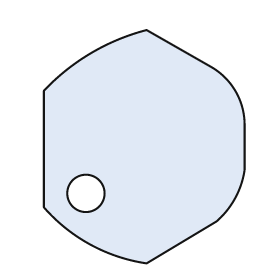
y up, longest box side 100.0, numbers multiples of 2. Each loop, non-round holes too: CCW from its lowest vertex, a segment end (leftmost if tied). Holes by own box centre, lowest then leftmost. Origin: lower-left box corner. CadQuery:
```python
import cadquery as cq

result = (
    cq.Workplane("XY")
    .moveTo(44.0, 0.0)
    .lineTo(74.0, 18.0)
    .threePointArc((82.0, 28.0), (86.0, 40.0))
    .lineTo(86.0, 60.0)
    .threePointArc((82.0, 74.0), (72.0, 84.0))
    .lineTo(44.0, 100.0)
    .threePointArc((20.0, 90.0), (0.0, 74.0))
    .lineTo(0.0, 24.0)
    .threePointArc((20.0, 8.0), (44.0, 0.0))
    .close()
    .moveTo(18.0, 30.0)
    .circle(8.0)
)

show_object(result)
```